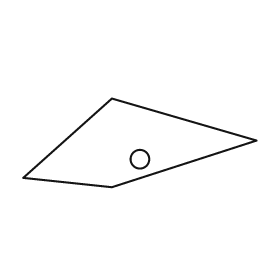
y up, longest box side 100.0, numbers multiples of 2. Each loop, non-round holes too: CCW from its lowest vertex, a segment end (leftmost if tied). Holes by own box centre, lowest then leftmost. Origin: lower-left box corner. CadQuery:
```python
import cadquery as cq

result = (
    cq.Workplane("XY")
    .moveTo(38.0, 0.0)
    .lineTo(100.0, 20.0)
    .lineTo(38.0, 38.0)
    .lineTo(0.0, 4.0)
    .close()
    .moveTo(50.0, 12.0)
    .circle(4.0)
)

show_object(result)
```